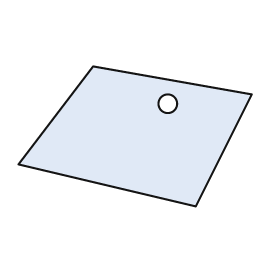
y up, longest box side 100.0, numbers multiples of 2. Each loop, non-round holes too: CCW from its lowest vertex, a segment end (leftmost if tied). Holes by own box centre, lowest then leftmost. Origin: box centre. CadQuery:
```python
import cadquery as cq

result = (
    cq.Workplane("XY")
    .moveTo(26.0, -30.0)
    .lineTo(50.0, 18.0)
    .lineTo(-18.0, 30.0)
    .lineTo(-50.0, -12.0)
    .close()
    .moveTo(14.0, 14.0)
    .circle(4.0)
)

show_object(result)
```